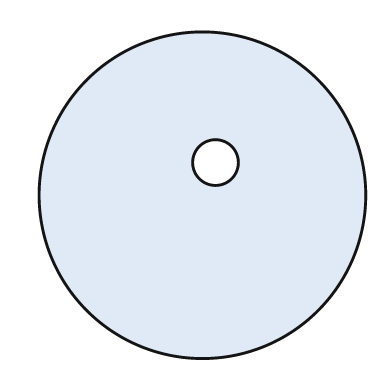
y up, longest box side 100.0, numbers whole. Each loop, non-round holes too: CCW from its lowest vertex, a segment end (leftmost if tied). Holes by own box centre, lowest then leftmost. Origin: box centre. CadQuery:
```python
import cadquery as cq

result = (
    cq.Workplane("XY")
    .moveTo(0.0, 0.0)
    .circle(50.0)
    .moveTo(4.0, 10.0)
    .circle(7.0)
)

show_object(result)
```